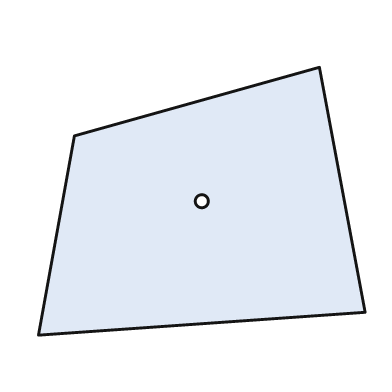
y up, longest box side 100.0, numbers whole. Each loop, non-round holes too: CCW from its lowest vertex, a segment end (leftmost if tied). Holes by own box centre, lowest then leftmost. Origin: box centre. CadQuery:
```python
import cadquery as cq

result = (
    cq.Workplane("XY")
    .moveTo(-50.0, -41.0)
    .lineTo(50.0, -34.0)
    .lineTo(36.0, 41.0)
    .lineTo(-39.0, 20.0)
    .close()
    .moveTo(0.0, 0.0)
    .circle(2.0)
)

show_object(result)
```